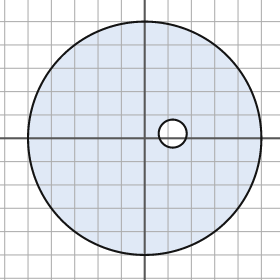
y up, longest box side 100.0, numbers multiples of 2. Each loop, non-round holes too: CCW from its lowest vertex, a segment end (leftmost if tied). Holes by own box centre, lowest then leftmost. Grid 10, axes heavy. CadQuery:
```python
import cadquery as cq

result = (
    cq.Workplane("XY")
    .moveTo(0.0, 0.0)
    .circle(50.0)
    .moveTo(12.0, 2.0)
    .circle(6.0)
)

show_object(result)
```